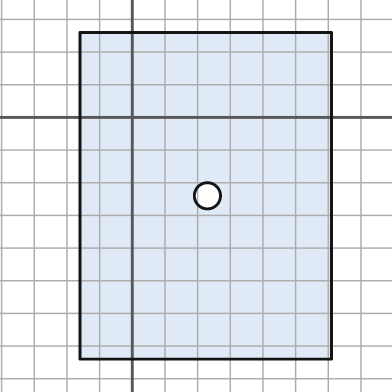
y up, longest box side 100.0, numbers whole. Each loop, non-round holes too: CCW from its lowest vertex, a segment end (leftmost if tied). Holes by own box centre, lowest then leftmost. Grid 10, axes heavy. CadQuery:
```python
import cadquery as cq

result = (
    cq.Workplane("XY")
    .moveTo(-16.0, -74.0)
    .lineTo(61.0, -74.0)
    .lineTo(61.0, 26.0)
    .lineTo(-16.0, 26.0)
    .close()
    .moveTo(23.0, -24.0)
    .circle(4.0)
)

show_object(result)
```